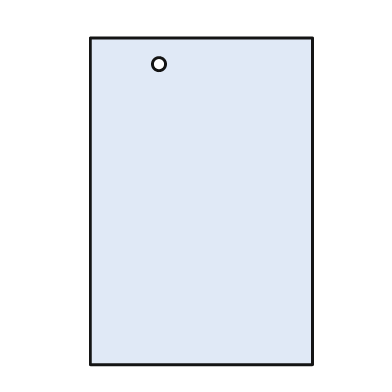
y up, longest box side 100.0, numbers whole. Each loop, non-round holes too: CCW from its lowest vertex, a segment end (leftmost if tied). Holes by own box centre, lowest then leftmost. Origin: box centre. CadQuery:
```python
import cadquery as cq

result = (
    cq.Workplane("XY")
    .moveTo(-34.0, -50.0)
    .lineTo(34.0, -50.0)
    .lineTo(34.0, 50.0)
    .lineTo(-34.0, 50.0)
    .close()
    .moveTo(-13.0, 42.0)
    .circle(2.0)
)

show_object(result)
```